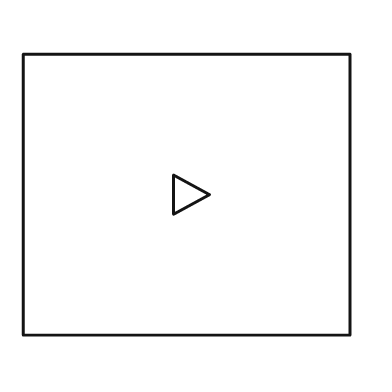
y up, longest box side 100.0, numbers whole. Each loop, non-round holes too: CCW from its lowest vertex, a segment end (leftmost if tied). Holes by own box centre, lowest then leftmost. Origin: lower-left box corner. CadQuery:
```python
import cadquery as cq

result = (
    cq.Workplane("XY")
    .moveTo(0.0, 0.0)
    .lineTo(100.0, 0.0)
    .lineTo(100.0, 86.0)
    .lineTo(0.0, 86.0)
    .close()
    .moveTo(46.0, 37.0)
    .lineTo(57.0, 43.0)
    .lineTo(46.0, 49.0)
    .close()
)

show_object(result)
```